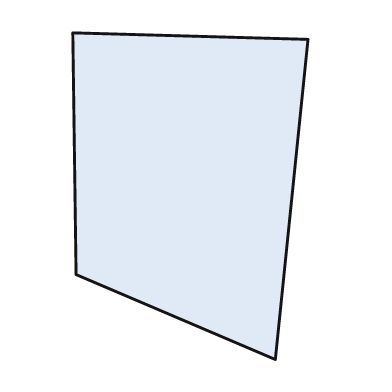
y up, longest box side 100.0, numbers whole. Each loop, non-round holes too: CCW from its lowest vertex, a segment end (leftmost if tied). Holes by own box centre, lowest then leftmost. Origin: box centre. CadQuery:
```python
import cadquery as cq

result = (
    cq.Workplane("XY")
    .moveTo(26.0, -50.0)
    .lineTo(36.0, 48.0)
    .lineTo(-36.0, 50.0)
    .lineTo(-35.0, -24.0)
    .close()
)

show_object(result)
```